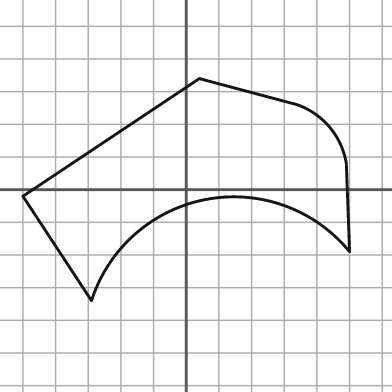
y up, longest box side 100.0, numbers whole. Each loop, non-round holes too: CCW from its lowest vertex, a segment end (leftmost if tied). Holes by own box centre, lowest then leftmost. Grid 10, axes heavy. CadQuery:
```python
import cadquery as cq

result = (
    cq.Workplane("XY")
    .moveTo(-29.0, -34.0)
    .threePointArc((6.0, -3.0), (50.0, -19.0))
    .lineTo(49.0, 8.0)
    .threePointArc((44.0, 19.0), (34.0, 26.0))
    .lineTo(4.0, 34.0)
    .lineTo(-50.0, -2.0)
    .close()
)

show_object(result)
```